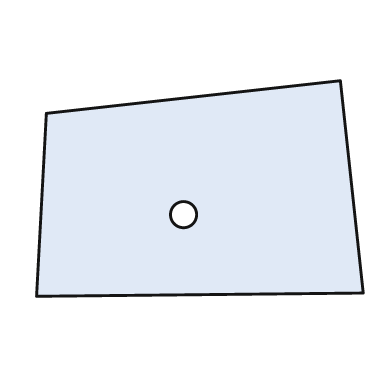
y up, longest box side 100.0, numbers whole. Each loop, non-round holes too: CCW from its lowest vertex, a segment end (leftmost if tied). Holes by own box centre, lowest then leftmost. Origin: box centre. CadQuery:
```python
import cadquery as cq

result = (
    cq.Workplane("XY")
    .moveTo(-50.0, -33.0)
    .lineTo(50.0, -32.0)
    .lineTo(43.0, 33.0)
    .lineTo(-47.0, 23.0)
    .close()
    .moveTo(-5.0, -8.0)
    .circle(4.0)
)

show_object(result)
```